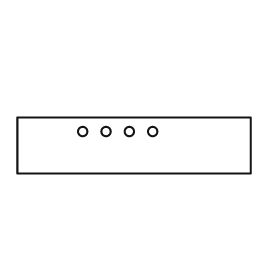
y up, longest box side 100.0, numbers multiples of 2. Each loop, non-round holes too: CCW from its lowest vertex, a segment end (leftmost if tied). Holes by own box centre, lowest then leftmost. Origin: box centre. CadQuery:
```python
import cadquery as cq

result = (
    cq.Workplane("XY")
    .moveTo(-50.0, -12.0)
    .lineTo(50.0, -12.0)
    .lineTo(50.0, 12.0)
    .lineTo(-50.0, 12.0)
    .close()
    .moveTo(-22.0, 6.0)
    .circle(2.0)
    .moveTo(-12.0, 6.0)
    .circle(2.0)
    .moveTo(-2.0, 6.0)
    .circle(2.0)
    .moveTo(8.0, 6.0)
    .circle(2.0)
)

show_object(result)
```